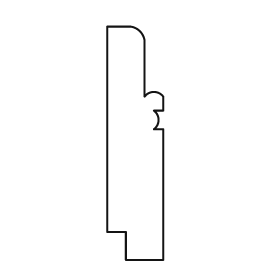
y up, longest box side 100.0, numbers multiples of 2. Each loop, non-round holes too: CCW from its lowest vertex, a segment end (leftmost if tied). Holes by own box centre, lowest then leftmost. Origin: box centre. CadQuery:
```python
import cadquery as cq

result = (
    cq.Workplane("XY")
    .moveTo(-4.0, -50.0)
    .lineTo(12.0, -50.0)
    .lineTo(12.0, 6.0)
    .lineTo(8.0, 6.0)
    .threePointArc((10.0, 10.0), (8.0, 14.0))
    .lineTo(12.0, 14.0)
    .lineTo(12.0, 20.0)
    .threePointArc((8.0, 22.0), (4.0, 20.0))
    .lineTo(4.0, 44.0)
    .threePointArc((2.0, 48.0), (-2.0, 50.0))
    .lineTo(-12.0, 50.0)
    .lineTo(-12.0, -38.0)
    .lineTo(-4.0, -38.0)
    .close()
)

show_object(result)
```